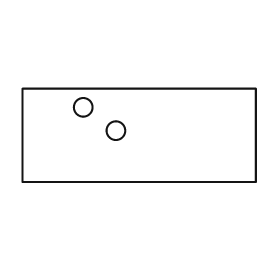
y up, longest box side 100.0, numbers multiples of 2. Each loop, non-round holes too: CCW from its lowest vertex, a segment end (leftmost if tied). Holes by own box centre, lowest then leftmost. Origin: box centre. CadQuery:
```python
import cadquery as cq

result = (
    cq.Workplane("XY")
    .moveTo(-50.0, -20.0)
    .lineTo(50.0, -20.0)
    .lineTo(50.0, 20.0)
    .lineTo(-50.0, 20.0)
    .close()
    .moveTo(-10.0, 2.0)
    .circle(4.0)
    .moveTo(-24.0, 12.0)
    .circle(4.0)
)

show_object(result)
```